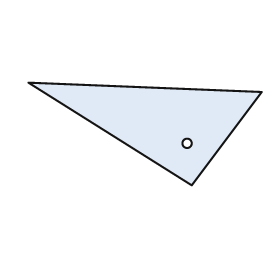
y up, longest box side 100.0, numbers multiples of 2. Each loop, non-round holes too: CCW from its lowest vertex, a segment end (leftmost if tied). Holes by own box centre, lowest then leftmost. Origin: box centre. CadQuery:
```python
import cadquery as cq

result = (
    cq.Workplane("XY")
    .moveTo(20.0, -22.0)
    .lineTo(50.0, 18.0)
    .lineTo(-50.0, 22.0)
    .close()
    .moveTo(18.0, -4.0)
    .circle(2.0)
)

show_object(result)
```